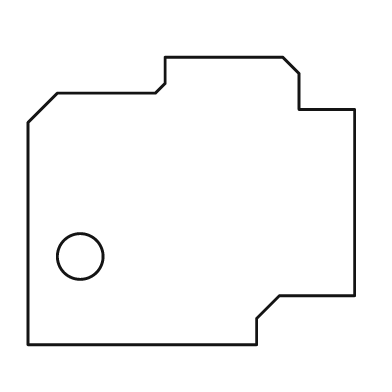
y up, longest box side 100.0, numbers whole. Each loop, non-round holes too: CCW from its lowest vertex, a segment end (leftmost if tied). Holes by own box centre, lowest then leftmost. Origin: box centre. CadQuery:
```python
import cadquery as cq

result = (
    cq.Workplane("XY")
    .moveTo(-50.0, -44.0)
    .lineTo(20.0, -44.0)
    .lineTo(20.0, -36.0)
    .lineTo(27.0, -29.0)
    .lineTo(50.0, -29.0)
    .lineTo(50.0, 28.0)
    .lineTo(33.0, 28.0)
    .lineTo(33.0, 39.0)
    .lineTo(28.0, 44.0)
    .lineTo(-8.0, 44.0)
    .lineTo(-8.0, 36.0)
    .lineTo(-11.0, 33.0)
    .lineTo(-41.0, 33.0)
    .lineTo(-50.0, 24.0)
    .close()
    .moveTo(-34.0, -17.0)
    .circle(7.0)
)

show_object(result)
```